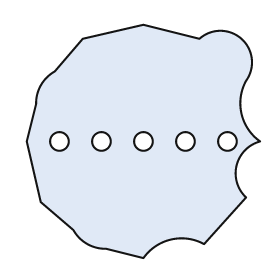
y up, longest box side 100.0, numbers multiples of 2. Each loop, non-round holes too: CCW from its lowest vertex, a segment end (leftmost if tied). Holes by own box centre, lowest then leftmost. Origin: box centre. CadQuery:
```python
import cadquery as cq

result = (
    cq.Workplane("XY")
    .moveTo(0.0, -50.0)
    .threePointArc((12.0, -42.0), (26.0, -44.0))
    .lineTo(44.0, -24.0)
    .threePointArc((40.0, -10.0), (50.0, 0.0))
    .threePointArc((42.0, 12.0), (44.0, 26.0))
    .threePointArc((42.0, 44.0), (24.0, 44.0))
    .lineTo(0.0, 50.0)
    .lineTo(-26.0, 44.0)
    .lineTo(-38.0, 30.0)
    .threePointArc((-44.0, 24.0), (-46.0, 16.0))
    .lineTo(-50.0, 0.0)
    .lineTo(-44.0, -26.0)
    .lineTo(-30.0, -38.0)
    .threePointArc((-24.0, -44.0), (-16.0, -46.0))
    .close()
    .moveTo(-36.0, 0.0)
    .circle(4.0)
    .moveTo(-18.0, 0.0)
    .circle(4.0)
    .moveTo(0.0, 0.0)
    .circle(4.0)
    .moveTo(18.0, 0.0)
    .circle(4.0)
    .moveTo(36.0, 0.0)
    .circle(4.0)
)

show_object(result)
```